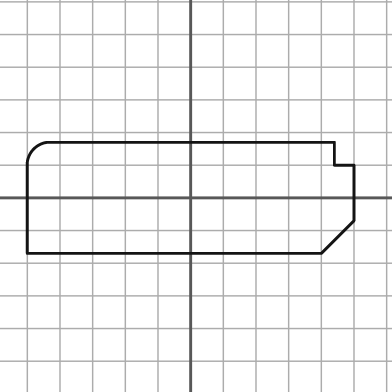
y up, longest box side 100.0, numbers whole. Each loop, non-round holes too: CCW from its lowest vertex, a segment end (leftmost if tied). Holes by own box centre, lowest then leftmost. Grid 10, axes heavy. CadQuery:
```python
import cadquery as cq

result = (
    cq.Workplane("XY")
    .moveTo(-50.0, -17.0)
    .lineTo(40.0, -17.0)
    .lineTo(50.0, -7.0)
    .lineTo(50.0, 10.0)
    .lineTo(44.0, 10.0)
    .lineTo(44.0, 17.0)
    .lineTo(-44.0, 17.0)
    .threePointArc((-48.0, 15.0), (-50.0, 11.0))
    .close()
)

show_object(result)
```